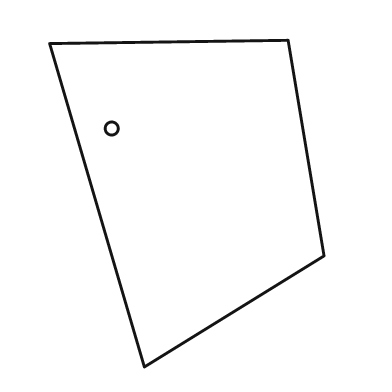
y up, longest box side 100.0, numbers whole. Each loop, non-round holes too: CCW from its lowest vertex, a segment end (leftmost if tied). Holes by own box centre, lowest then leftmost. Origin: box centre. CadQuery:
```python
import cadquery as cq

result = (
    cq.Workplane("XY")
    .moveTo(-13.0, -50.0)
    .lineTo(42.0, -16.0)
    .lineTo(31.0, 50.0)
    .lineTo(-42.0, 49.0)
    .close()
    .moveTo(-23.0, 23.0)
    .circle(2.0)
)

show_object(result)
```